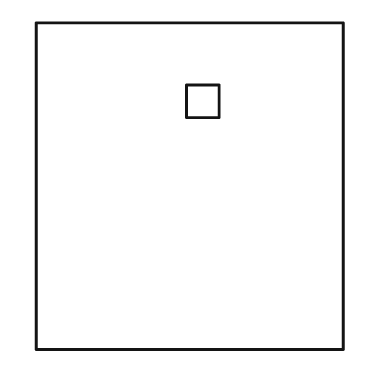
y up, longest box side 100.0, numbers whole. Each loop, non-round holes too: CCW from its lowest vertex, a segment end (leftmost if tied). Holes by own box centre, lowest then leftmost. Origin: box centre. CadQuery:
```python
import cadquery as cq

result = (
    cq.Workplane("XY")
    .moveTo(-47.0, -50.0)
    .lineTo(47.0, -50.0)
    .lineTo(47.0, 50.0)
    .lineTo(-47.0, 50.0)
    .close()
    .moveTo(-1.0, 21.0)
    .lineTo(9.0, 21.0)
    .lineTo(9.0, 31.0)
    .lineTo(-1.0, 31.0)
    .close()
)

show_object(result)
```